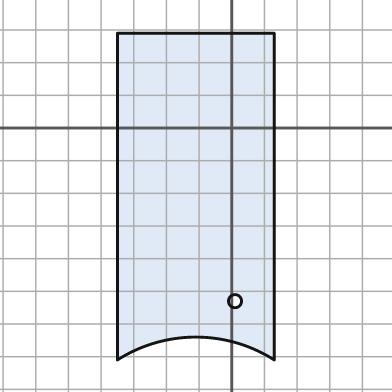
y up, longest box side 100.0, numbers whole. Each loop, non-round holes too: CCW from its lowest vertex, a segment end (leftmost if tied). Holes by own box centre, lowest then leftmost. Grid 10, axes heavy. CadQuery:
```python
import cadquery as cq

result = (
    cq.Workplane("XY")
    .moveTo(-35.0, -71.0)
    .threePointArc((-11.0, -64.0), (13.0, -71.0))
    .lineTo(13.0, 29.0)
    .lineTo(-35.0, 29.0)
    .close()
    .moveTo(1.0, -53.0)
    .circle(2.0)
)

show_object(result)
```